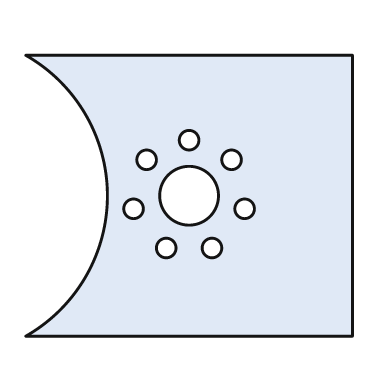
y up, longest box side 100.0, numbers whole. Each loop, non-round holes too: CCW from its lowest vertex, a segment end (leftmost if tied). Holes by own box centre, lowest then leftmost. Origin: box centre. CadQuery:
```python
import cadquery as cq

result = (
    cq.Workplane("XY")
    .moveTo(-50.0, -43.0)
    .lineTo(50.0, -43.0)
    .lineTo(50.0, 43.0)
    .lineTo(-50.0, 43.0)
    .threePointArc((-25.0, 0.0), (-50.0, -43.0))
    .close()
    .moveTo(-7.0, -16.0)
    .circle(3.0)
    .moveTo(7.0, -16.0)
    .circle(3.0)
    .moveTo(-17.0, -4.0)
    .circle(3.0)
    .moveTo(17.0, -4.0)
    .circle(3.0)
    .moveTo(0.0, 0.0)
    .circle(9.0)
    .moveTo(-13.0, 11.0)
    .circle(3.0)
    .moveTo(13.0, 11.0)
    .circle(3.0)
    .moveTo(0.0, 17.0)
    .circle(3.0)
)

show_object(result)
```